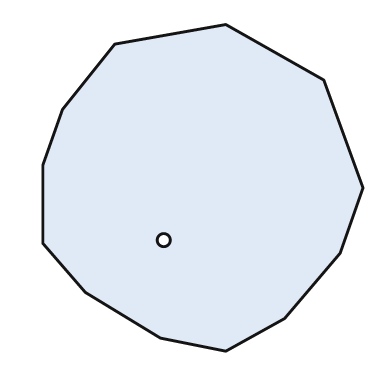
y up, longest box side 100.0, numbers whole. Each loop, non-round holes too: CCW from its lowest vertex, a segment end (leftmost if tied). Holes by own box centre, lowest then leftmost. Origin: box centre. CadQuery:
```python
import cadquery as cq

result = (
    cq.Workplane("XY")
    .moveTo(7.0, -50.0)
    .lineTo(25.0, -40.0)
    .lineTo(42.0, -20.0)
    .lineTo(49.0, 0.0)
    .lineTo(37.0, 33.0)
    .lineTo(7.0, 50.0)
    .lineTo(-27.0, 44.0)
    .lineTo(-43.0, 24.0)
    .lineTo(-49.0, 7.0)
    .lineTo(-49.0, -17.0)
    .lineTo(-36.0, -32.0)
    .lineTo(-13.0, -46.0)
    .close()
    .moveTo(-12.0, -16.0)
    .circle(2.0)
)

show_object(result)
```